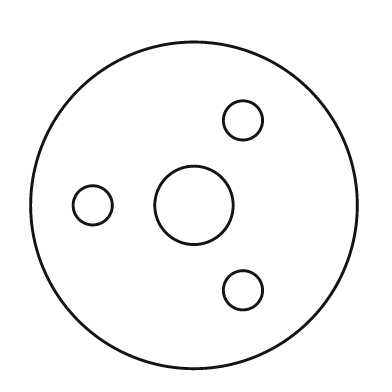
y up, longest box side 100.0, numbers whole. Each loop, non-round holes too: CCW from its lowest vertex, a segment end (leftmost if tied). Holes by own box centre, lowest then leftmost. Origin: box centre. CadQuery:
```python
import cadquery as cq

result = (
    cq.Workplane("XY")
    .moveTo(0.0, 0.0)
    .circle(50.0)
    .moveTo(15.0, -26.0)
    .circle(6.0)
    .moveTo(-31.0, 0.0)
    .circle(6.0)
    .moveTo(0.0, 0.0)
    .circle(12.0)
    .moveTo(15.0, 26.0)
    .circle(6.0)
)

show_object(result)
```